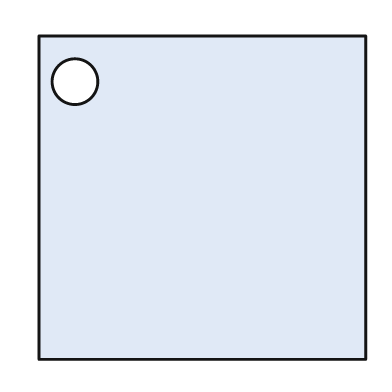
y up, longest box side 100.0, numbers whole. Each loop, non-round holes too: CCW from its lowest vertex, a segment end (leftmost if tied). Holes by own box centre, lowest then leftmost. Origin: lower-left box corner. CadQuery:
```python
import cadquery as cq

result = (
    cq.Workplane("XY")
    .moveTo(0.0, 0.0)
    .lineTo(100.0, 0.0)
    .lineTo(100.0, 99.0)
    .lineTo(0.0, 99.0)
    .close()
    .moveTo(11.0, 85.0)
    .circle(7.0)
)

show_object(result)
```